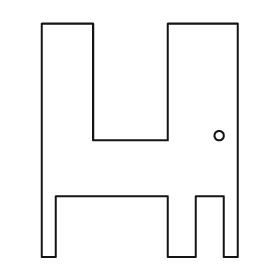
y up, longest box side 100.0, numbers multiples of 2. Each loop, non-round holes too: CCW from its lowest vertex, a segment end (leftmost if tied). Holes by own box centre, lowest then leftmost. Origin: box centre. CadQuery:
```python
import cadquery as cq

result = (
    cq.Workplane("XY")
    .moveTo(-42.0, -50.0)
    .lineTo(-36.0, -50.0)
    .lineTo(-36.0, -24.0)
    .lineTo(12.0, -24.0)
    .lineTo(12.0, -50.0)
    .lineTo(24.0, -50.0)
    .lineTo(24.0, -24.0)
    .lineTo(36.0, -24.0)
    .lineTo(36.0, -50.0)
    .lineTo(42.0, -50.0)
    .lineTo(42.0, 50.0)
    .lineTo(12.0, 50.0)
    .lineTo(12.0, 0.0)
    .lineTo(-20.0, 0.0)
    .lineTo(-20.0, 50.0)
    .lineTo(-42.0, 50.0)
    .close()
    .moveTo(34.0, 2.0)
    .circle(2.0)
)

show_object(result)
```